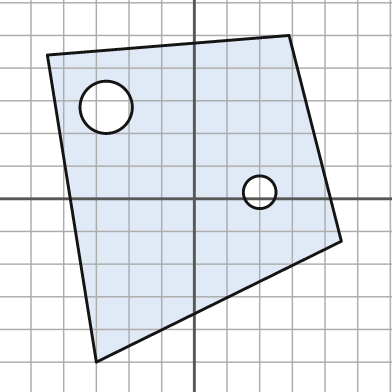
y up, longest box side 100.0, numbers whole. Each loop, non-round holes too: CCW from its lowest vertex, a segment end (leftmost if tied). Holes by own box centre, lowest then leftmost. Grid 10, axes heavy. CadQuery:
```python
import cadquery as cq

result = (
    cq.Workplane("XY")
    .moveTo(-30.0, -50.0)
    .lineTo(45.0, -13.0)
    .lineTo(29.0, 50.0)
    .lineTo(-45.0, 44.0)
    .close()
    .moveTo(20.0, 2.0)
    .circle(5.0)
    .moveTo(-27.0, 28.0)
    .circle(8.0)
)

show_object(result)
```